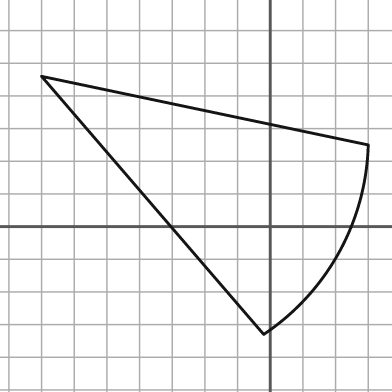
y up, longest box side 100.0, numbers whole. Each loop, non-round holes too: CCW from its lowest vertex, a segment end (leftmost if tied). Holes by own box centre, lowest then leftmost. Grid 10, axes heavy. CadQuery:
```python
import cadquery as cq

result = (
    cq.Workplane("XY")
    .moveTo(-2.0, -33.0)
    .threePointArc((21.0, -8.0), (30.0, 25.0))
    .lineTo(-70.0, 46.0)
    .close()
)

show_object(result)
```